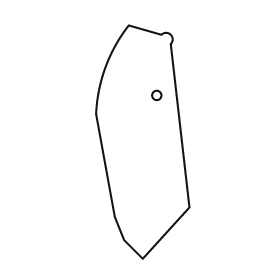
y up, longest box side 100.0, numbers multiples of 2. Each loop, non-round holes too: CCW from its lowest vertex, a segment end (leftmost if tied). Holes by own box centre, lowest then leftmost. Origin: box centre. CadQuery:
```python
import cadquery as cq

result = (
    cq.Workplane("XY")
    .moveTo(0.0, -50.0)
    .lineTo(20.0, -28.0)
    .lineTo(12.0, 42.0)
    .threePointArc((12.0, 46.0), (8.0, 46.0))
    .lineTo(-6.0, 50.0)
    .threePointArc((-16.0, 32.0), (-20.0, 12.0))
    .lineTo(-12.0, -32.0)
    .lineTo(-8.0, -42.0)
    .close()
    .moveTo(6.0, 20.0)
    .circle(2.0)
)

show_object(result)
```